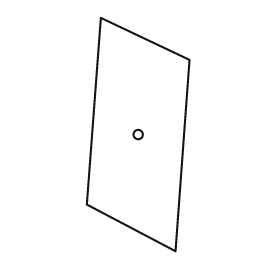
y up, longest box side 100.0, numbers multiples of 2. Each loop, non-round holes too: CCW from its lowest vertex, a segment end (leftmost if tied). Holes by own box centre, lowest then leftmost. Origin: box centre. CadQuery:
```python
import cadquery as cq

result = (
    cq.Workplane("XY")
    .moveTo(16.0, -50.0)
    .lineTo(22.0, 32.0)
    .lineTo(-16.0, 50.0)
    .lineTo(-22.0, -30.0)
    .close()
    .moveTo(0.0, 0.0)
    .circle(2.0)
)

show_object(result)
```